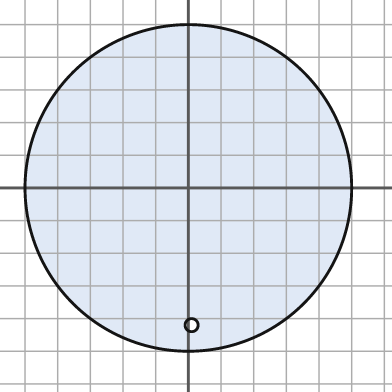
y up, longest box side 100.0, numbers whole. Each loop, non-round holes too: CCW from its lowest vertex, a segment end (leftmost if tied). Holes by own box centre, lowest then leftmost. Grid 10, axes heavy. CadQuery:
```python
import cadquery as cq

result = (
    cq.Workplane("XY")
    .moveTo(0.0, 0.0)
    .circle(50.0)
    .moveTo(1.0, -42.0)
    .circle(2.0)
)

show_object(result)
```